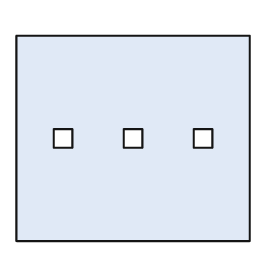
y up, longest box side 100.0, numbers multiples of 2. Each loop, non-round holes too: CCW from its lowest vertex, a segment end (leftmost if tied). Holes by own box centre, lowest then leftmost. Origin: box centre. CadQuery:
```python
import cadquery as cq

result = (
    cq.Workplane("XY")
    .moveTo(-50.0, -44.0)
    .lineTo(50.0, -44.0)
    .lineTo(50.0, 44.0)
    .lineTo(-50.0, 44.0)
    .close()
    .moveTo(-34.0, -4.0)
    .lineTo(-26.0, -4.0)
    .lineTo(-26.0, 4.0)
    .lineTo(-34.0, 4.0)
    .close()
    .moveTo(-4.0, -4.0)
    .lineTo(4.0, -4.0)
    .lineTo(4.0, 4.0)
    .lineTo(-4.0, 4.0)
    .close()
    .moveTo(26.0, -4.0)
    .lineTo(34.0, -4.0)
    .lineTo(34.0, 4.0)
    .lineTo(26.0, 4.0)
    .close()
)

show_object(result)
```